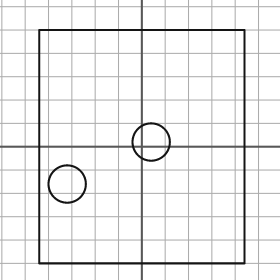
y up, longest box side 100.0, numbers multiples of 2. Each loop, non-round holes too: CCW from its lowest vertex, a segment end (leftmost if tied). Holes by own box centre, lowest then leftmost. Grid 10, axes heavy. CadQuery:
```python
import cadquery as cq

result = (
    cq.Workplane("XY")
    .moveTo(-44.0, -50.0)
    .lineTo(44.0, -50.0)
    .lineTo(44.0, 50.0)
    .lineTo(-44.0, 50.0)
    .close()
    .moveTo(-32.0, -16.0)
    .circle(8.0)
    .moveTo(4.0, 2.0)
    .circle(8.0)
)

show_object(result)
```